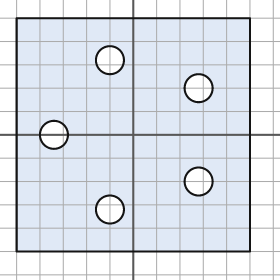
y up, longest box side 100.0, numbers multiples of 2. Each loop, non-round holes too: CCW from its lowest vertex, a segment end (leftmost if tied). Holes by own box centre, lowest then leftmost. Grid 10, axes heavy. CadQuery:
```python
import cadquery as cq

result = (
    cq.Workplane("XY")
    .moveTo(-50.0, -50.0)
    .lineTo(50.0, -50.0)
    .lineTo(50.0, 50.0)
    .lineTo(-50.0, 50.0)
    .close()
    .moveTo(-10.0, -32.0)
    .circle(6.0)
    .moveTo(28.0, -20.0)
    .circle(6.0)
    .moveTo(-34.0, 0.0)
    .circle(6.0)
    .moveTo(28.0, 20.0)
    .circle(6.0)
    .moveTo(-10.0, 32.0)
    .circle(6.0)
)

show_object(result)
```